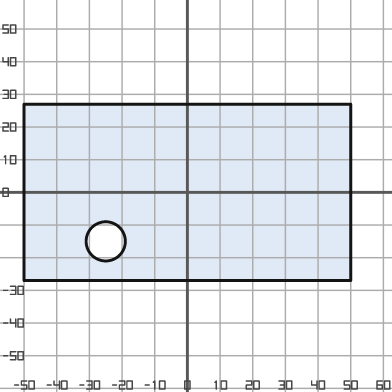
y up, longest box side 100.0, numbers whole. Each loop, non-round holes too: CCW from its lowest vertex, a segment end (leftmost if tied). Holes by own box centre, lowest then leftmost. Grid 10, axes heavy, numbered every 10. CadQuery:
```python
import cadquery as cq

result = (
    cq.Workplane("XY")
    .moveTo(-50.0, -27.0)
    .lineTo(50.0, -27.0)
    .lineTo(50.0, 27.0)
    .lineTo(-50.0, 27.0)
    .close()
    .moveTo(-25.0, -15.0)
    .circle(6.0)
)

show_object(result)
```